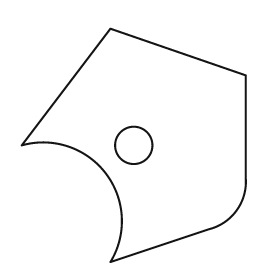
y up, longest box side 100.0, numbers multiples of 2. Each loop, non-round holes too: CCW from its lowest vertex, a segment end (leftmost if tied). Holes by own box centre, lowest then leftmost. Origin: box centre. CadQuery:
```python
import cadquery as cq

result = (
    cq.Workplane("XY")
    .moveTo(-10.0, -50.0)
    .lineTo(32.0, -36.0)
    .threePointArc((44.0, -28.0), (48.0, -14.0))
    .lineTo(48.0, 30.0)
    .lineTo(-10.0, 50.0)
    .lineTo(-48.0, 0.0)
    .threePointArc((-12.0, -12.0), (-10.0, -50.0))
    .close()
    .moveTo(0.0, 0.0)
    .circle(8.0)
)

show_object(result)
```